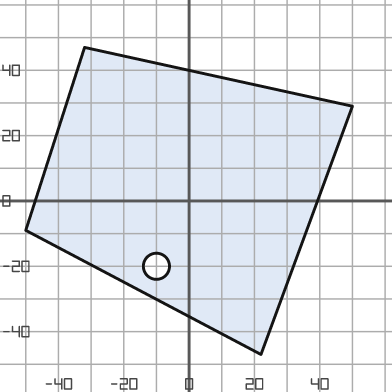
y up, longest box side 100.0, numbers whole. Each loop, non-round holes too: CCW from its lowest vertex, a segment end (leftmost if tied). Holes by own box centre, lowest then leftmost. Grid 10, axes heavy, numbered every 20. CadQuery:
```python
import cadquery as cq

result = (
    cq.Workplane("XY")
    .moveTo(22.0, -47.0)
    .lineTo(50.0, 29.0)
    .lineTo(-32.0, 47.0)
    .lineTo(-50.0, -9.0)
    .close()
    .moveTo(-10.0, -20.0)
    .circle(4.0)
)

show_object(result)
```